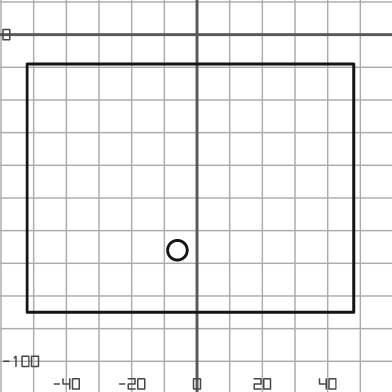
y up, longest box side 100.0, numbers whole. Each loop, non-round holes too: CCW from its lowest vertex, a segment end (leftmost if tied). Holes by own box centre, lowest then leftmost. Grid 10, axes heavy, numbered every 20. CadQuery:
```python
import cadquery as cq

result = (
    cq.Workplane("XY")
    .moveTo(-52.0, -85.0)
    .lineTo(48.0, -85.0)
    .lineTo(48.0, -9.0)
    .lineTo(-52.0, -9.0)
    .close()
    .moveTo(-6.0, -66.0)
    .circle(3.0)
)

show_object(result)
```